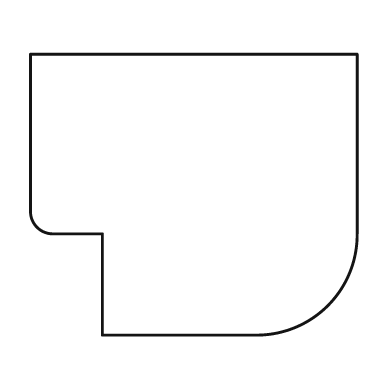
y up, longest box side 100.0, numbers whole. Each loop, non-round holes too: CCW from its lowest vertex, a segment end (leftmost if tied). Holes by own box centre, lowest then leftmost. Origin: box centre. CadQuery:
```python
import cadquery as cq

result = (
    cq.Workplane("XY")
    .moveTo(-28.0, -43.0)
    .lineTo(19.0, -43.0)
    .threePointArc((41.0, -34.0), (50.0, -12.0))
    .lineTo(50.0, 43.0)
    .lineTo(-50.0, 43.0)
    .lineTo(-50.0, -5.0)
    .threePointArc((-48.0, -10.0), (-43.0, -12.0))
    .lineTo(-28.0, -12.0)
    .close()
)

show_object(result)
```